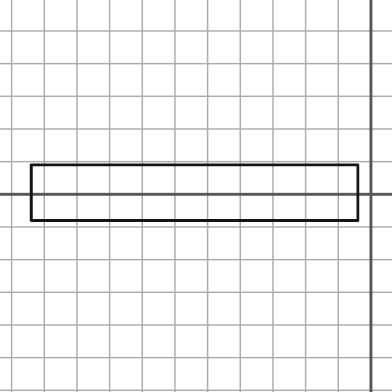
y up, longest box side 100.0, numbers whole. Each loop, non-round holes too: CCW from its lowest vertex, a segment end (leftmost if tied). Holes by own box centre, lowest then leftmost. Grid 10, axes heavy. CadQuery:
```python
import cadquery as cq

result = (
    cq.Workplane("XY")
    .moveTo(-104.0, -8.0)
    .lineTo(-4.0, -8.0)
    .lineTo(-4.0, 9.0)
    .lineTo(-104.0, 9.0)
    .close()
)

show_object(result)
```